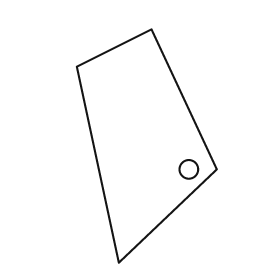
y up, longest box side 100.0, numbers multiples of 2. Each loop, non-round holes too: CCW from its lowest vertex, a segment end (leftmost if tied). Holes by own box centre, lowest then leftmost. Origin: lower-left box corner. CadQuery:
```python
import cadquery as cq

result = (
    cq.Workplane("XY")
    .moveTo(18.0, 0.0)
    .lineTo(60.0, 40.0)
    .lineTo(32.0, 100.0)
    .lineTo(0.0, 84.0)
    .close()
    .moveTo(48.0, 40.0)
    .circle(4.0)
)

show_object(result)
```